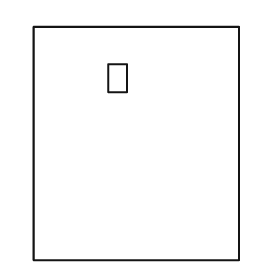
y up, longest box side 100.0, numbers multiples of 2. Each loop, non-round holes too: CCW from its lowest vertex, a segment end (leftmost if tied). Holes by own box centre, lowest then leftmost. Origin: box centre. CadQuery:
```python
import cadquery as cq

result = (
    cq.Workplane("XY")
    .moveTo(-44.0, -50.0)
    .lineTo(44.0, -50.0)
    .lineTo(44.0, 50.0)
    .lineTo(-44.0, 50.0)
    .close()
    .moveTo(-12.0, 22.0)
    .lineTo(-4.0, 22.0)
    .lineTo(-4.0, 34.0)
    .lineTo(-12.0, 34.0)
    .close()
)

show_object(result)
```